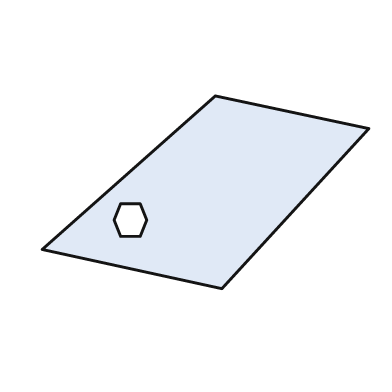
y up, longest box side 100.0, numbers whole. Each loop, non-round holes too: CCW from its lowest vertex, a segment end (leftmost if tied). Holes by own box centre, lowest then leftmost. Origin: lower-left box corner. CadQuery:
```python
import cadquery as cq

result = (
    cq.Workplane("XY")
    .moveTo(55.0, 0.0)
    .lineTo(100.0, 49.0)
    .lineTo(53.0, 59.0)
    .lineTo(0.0, 12.0)
    .close()
    .moveTo(24.0, 16.0)
    .lineTo(30.0, 16.0)
    .lineTo(32.0, 21.0)
    .lineTo(30.0, 26.0)
    .lineTo(24.0, 26.0)
    .lineTo(22.0, 21.0)
    .close()
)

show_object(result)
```